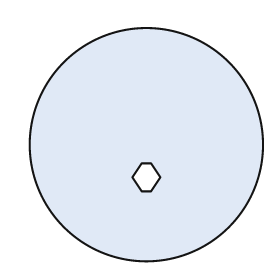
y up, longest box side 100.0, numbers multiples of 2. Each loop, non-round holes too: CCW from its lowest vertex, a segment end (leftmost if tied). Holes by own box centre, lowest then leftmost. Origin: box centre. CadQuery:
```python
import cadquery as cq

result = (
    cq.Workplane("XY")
    .moveTo(0.0, 0.0)
    .circle(50.0)
    .moveTo(-2.0, -20.0)
    .lineTo(2.0, -20.0)
    .lineTo(6.0, -14.0)
    .lineTo(2.0, -8.0)
    .lineTo(-2.0, -8.0)
    .lineTo(-6.0, -14.0)
    .close()
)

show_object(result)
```